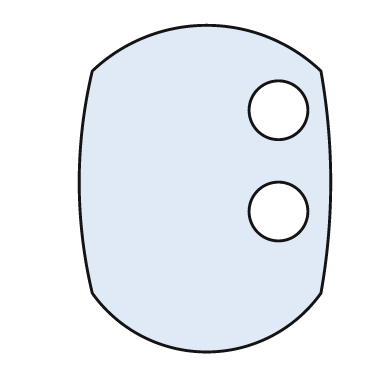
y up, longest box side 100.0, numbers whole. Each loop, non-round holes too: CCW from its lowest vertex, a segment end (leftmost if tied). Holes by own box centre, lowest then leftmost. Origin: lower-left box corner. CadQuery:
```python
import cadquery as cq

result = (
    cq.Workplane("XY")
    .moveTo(4.0, 18.0)
    .threePointArc((39.0, 0.0), (74.0, 18.0))
    .threePointArc((77.0, 52.0), (74.0, 86.0))
    .threePointArc((39.0, 100.0), (4.0, 86.0))
    .threePointArc((0.0, 52.0), (4.0, 18.0))
    .close()
    .moveTo(61.0, 43.0)
    .circle(9.0)
    .moveTo(61.0, 74.0)
    .circle(9.0)
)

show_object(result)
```